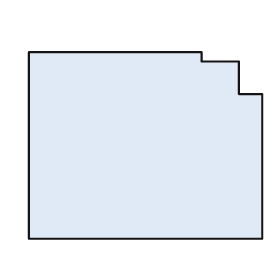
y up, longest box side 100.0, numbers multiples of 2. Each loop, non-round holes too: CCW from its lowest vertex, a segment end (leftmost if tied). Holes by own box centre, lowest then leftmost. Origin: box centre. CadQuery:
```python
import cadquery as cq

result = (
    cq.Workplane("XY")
    .moveTo(-50.0, -40.0)
    .lineTo(50.0, -40.0)
    .lineTo(50.0, 22.0)
    .lineTo(40.0, 22.0)
    .lineTo(40.0, 36.0)
    .lineTo(24.0, 36.0)
    .lineTo(24.0, 40.0)
    .lineTo(-50.0, 40.0)
    .close()
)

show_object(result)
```